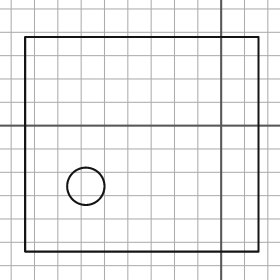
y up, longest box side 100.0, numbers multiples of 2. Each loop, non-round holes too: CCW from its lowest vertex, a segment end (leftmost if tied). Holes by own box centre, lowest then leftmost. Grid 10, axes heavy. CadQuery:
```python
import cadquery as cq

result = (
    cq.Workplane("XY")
    .moveTo(-84.0, -54.0)
    .lineTo(16.0, -54.0)
    .lineTo(16.0, 38.0)
    .lineTo(-84.0, 38.0)
    .close()
    .moveTo(-58.0, -26.0)
    .circle(8.0)
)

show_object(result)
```